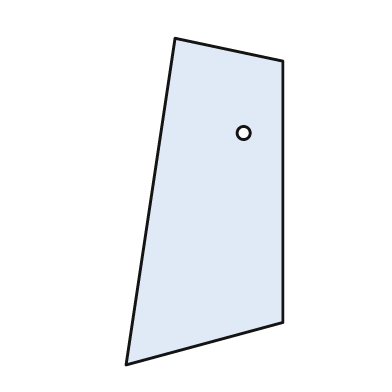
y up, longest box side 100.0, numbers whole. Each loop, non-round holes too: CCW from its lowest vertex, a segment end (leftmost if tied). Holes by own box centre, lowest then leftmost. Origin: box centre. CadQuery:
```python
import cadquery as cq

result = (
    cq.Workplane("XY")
    .moveTo(-24.0, -50.0)
    .lineTo(24.0, -37.0)
    .lineTo(24.0, 43.0)
    .lineTo(-9.0, 50.0)
    .close()
    .moveTo(12.0, 21.0)
    .circle(2.0)
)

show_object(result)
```